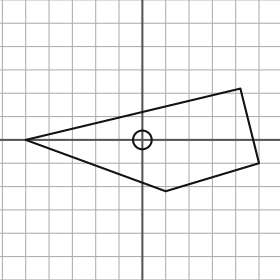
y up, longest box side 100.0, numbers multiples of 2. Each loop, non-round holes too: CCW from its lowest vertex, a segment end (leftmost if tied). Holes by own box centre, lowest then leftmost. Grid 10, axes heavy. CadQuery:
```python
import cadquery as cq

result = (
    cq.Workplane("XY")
    .moveTo(10.0, -22.0)
    .lineTo(50.0, -10.0)
    .lineTo(42.0, 22.0)
    .lineTo(-50.0, 0.0)
    .close()
    .moveTo(0.0, 0.0)
    .circle(4.0)
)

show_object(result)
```